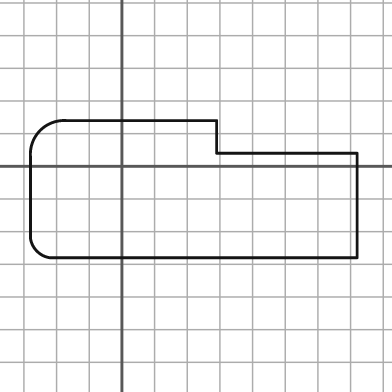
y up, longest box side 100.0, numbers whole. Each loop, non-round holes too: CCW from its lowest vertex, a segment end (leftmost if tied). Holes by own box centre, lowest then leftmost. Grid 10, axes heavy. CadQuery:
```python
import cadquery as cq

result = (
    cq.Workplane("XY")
    .moveTo(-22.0, -28.0)
    .lineTo(72.0, -28.0)
    .lineTo(72.0, 4.0)
    .lineTo(29.0, 4.0)
    .lineTo(29.0, 14.0)
    .lineTo(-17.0, 14.0)
    .threePointArc((-25.0, 11.0), (-28.0, 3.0))
    .lineTo(-28.0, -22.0)
    .threePointArc((-26.0, -26.0), (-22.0, -28.0))
    .close()
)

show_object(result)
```